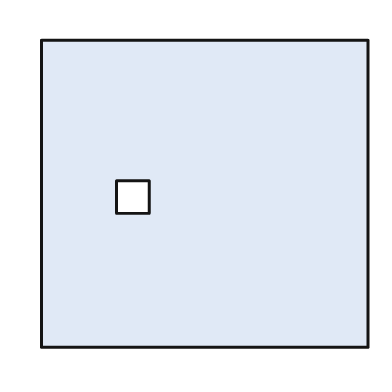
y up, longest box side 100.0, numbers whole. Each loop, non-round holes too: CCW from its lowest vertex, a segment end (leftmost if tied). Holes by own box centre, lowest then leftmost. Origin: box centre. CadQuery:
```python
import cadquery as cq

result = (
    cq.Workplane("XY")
    .moveTo(-50.0, -47.0)
    .lineTo(50.0, -47.0)
    .lineTo(50.0, 47.0)
    .lineTo(-50.0, 47.0)
    .close()
    .moveTo(-27.0, -6.0)
    .lineTo(-17.0, -6.0)
    .lineTo(-17.0, 4.0)
    .lineTo(-27.0, 4.0)
    .close()
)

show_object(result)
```